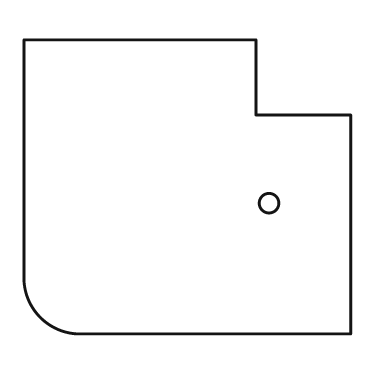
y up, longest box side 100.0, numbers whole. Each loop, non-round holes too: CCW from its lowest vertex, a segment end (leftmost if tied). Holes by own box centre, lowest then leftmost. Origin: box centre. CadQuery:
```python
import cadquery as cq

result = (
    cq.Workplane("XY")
    .moveTo(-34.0, -45.0)
    .lineTo(50.0, -45.0)
    .lineTo(50.0, 22.0)
    .lineTo(21.0, 22.0)
    .lineTo(21.0, 45.0)
    .lineTo(-50.0, 45.0)
    .lineTo(-50.0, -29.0)
    .threePointArc((-45.0, -40.0), (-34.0, -45.0))
    .close()
    .moveTo(25.0, -5.0)
    .circle(3.0)
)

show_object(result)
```